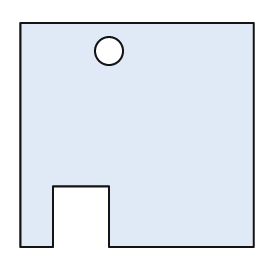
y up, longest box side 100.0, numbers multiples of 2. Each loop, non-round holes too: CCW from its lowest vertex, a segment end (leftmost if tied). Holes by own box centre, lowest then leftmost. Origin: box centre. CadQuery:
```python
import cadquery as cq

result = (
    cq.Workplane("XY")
    .moveTo(-50.0, -48.0)
    .lineTo(-36.0, -48.0)
    .lineTo(-36.0, -22.0)
    .lineTo(-12.0, -22.0)
    .lineTo(-12.0, -48.0)
    .lineTo(50.0, -48.0)
    .lineTo(50.0, 48.0)
    .lineTo(-50.0, 48.0)
    .close()
    .moveTo(-12.0, 36.0)
    .circle(6.0)
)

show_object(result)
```